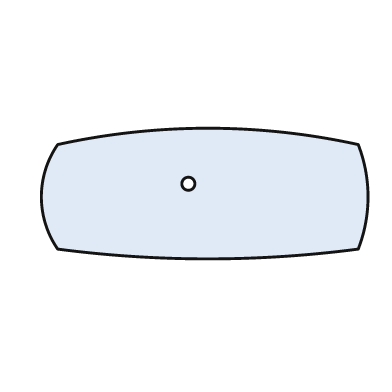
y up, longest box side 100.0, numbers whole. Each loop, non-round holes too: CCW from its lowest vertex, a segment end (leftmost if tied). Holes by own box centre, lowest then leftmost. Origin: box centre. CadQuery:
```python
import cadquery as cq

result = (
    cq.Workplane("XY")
    .moveTo(-45.0, -17.0)
    .threePointArc((1.0, -20.0), (47.0, -17.0))
    .threePointArc((50.0, -1.0), (47.0, 15.0))
    .threePointArc((1.0, 20.0), (-45.0, 15.0))
    .threePointArc((-50.0, -1.0), (-45.0, -17.0))
    .close()
    .moveTo(-5.0, 3.0)
    .circle(2.0)
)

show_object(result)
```